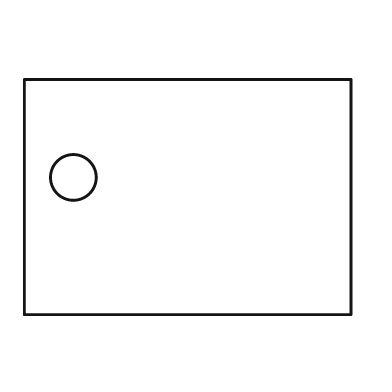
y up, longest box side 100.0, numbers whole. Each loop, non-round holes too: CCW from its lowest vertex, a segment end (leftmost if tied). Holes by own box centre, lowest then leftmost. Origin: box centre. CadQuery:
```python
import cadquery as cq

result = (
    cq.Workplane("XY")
    .moveTo(-50.0, -36.0)
    .lineTo(50.0, -36.0)
    .lineTo(50.0, 36.0)
    .lineTo(-50.0, 36.0)
    .close()
    .moveTo(-35.0, 6.0)
    .circle(7.0)
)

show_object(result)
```